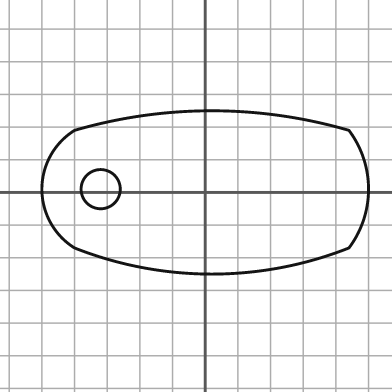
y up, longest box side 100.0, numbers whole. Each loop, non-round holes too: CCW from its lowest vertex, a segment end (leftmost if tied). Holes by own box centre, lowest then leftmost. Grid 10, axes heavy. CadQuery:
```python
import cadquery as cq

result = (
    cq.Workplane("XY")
    .moveTo(-40.0, -17.0)
    .threePointArc((2.0, -25.0), (44.0, -17.0))
    .threePointArc((50.0, 1.0), (44.0, 19.0))
    .threePointArc((2.0, 25.0), (-40.0, 19.0))
    .threePointArc((-50.0, 1.0), (-40.0, -17.0))
    .close()
    .moveTo(-32.0, 1.0)
    .circle(6.0)
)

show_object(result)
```